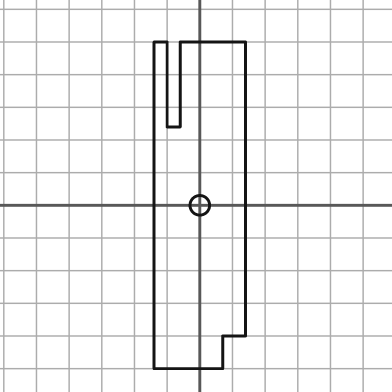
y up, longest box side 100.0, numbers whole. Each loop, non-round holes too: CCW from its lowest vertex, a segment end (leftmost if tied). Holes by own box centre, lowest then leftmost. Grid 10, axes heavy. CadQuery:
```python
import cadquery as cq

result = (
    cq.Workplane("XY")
    .moveTo(-14.0, -50.0)
    .lineTo(7.0, -50.0)
    .lineTo(7.0, -40.0)
    .lineTo(14.0, -40.0)
    .lineTo(14.0, 50.0)
    .lineTo(-6.0, 50.0)
    .lineTo(-6.0, 24.0)
    .lineTo(-10.0, 24.0)
    .lineTo(-10.0, 50.0)
    .lineTo(-14.0, 50.0)
    .close()
    .moveTo(0.0, 0.0)
    .circle(3.0)
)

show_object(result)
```